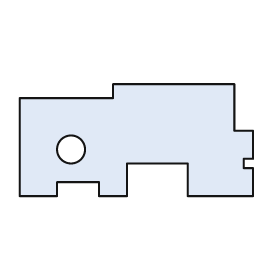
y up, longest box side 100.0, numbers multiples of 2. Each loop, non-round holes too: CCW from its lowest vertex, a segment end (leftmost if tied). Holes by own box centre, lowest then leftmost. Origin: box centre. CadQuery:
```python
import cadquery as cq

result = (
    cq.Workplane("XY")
    .moveTo(-50.0, -24.0)
    .lineTo(-34.0, -24.0)
    .lineTo(-34.0, -18.0)
    .lineTo(-16.0, -18.0)
    .lineTo(-16.0, -24.0)
    .lineTo(-4.0, -24.0)
    .lineTo(-4.0, -10.0)
    .lineTo(22.0, -10.0)
    .lineTo(22.0, -24.0)
    .lineTo(50.0, -24.0)
    .lineTo(50.0, -12.0)
    .lineTo(46.0, -12.0)
    .lineTo(46.0, -8.0)
    .lineTo(50.0, -8.0)
    .lineTo(50.0, 4.0)
    .lineTo(42.0, 4.0)
    .lineTo(42.0, 24.0)
    .lineTo(-10.0, 24.0)
    .lineTo(-10.0, 18.0)
    .lineTo(-50.0, 18.0)
    .close()
    .moveTo(-28.0, -4.0)
    .circle(6.0)
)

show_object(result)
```